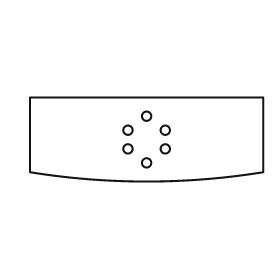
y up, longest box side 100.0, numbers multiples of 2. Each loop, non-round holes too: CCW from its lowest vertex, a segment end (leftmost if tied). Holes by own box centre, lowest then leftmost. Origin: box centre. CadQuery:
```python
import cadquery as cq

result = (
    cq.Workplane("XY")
    .moveTo(-50.0, -14.0)
    .threePointArc((0.0, -18.0), (50.0, -14.0))
    .lineTo(50.0, 18.0)
    .lineTo(-50.0, 18.0)
    .close()
    .moveTo(0.0, -10.0)
    .circle(2.0)
    .moveTo(-8.0, -4.0)
    .circle(2.0)
    .moveTo(8.0, -4.0)
    .circle(2.0)
    .moveTo(-8.0, 4.0)
    .circle(2.0)
    .moveTo(8.0, 4.0)
    .circle(2.0)
    .moveTo(0.0, 10.0)
    .circle(2.0)
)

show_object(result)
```